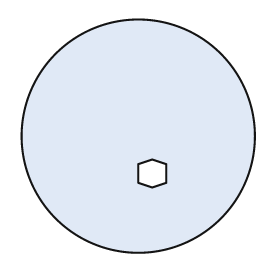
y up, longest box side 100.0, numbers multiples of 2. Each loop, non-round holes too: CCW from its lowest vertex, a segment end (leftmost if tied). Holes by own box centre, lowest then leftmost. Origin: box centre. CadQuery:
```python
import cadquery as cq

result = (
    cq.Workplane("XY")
    .moveTo(0.0, 0.0)
    .circle(50.0)
    .moveTo(6.0, -22.0)
    .lineTo(12.0, -20.0)
    .lineTo(12.0, -12.0)
    .lineTo(6.0, -10.0)
    .lineTo(0.0, -12.0)
    .lineTo(0.0, -20.0)
    .close()
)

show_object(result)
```